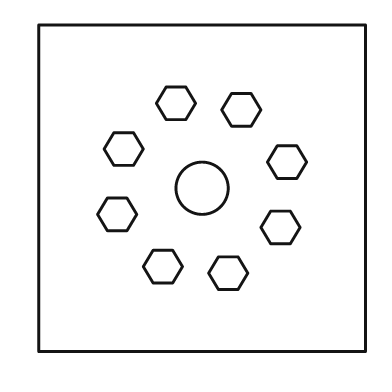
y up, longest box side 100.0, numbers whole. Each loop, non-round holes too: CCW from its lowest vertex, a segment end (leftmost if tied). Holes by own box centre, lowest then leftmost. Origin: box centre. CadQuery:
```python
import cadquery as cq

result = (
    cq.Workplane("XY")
    .moveTo(-50.0, -50.0)
    .lineTo(50.0, -50.0)
    .lineTo(50.0, 50.0)
    .lineTo(-50.0, 50.0)
    .close()
    .moveTo(5.0, -31.0)
    .lineTo(11.0, -31.0)
    .lineTo(14.0, -26.0)
    .lineTo(11.0, -21.0)
    .lineTo(5.0, -21.0)
    .lineTo(2.0, -26.0)
    .close()
    .moveTo(-15.0, -29.0)
    .lineTo(-9.0, -29.0)
    .lineTo(-6.0, -24.0)
    .lineTo(-9.0, -19.0)
    .lineTo(-15.0, -19.0)
    .lineTo(-18.0, -24.0)
    .close()
    .moveTo(21.0, -17.0)
    .lineTo(27.0, -17.0)
    .lineTo(30.0, -12.0)
    .lineTo(27.0, -7.0)
    .lineTo(21.0, -7.0)
    .lineTo(18.0, -12.0)
    .close()
    .moveTo(-29.0, -13.0)
    .lineTo(-23.0, -13.0)
    .lineTo(-20.0, -8.0)
    .lineTo(-23.0, -3.0)
    .lineTo(-29.0, -3.0)
    .lineTo(-32.0, -8.0)
    .close()
    .moveTo(0.0, 0.0)
    .circle(8.0)
    .moveTo(23.0, 3.0)
    .lineTo(29.0, 3.0)
    .lineTo(32.0, 8.0)
    .lineTo(29.0, 13.0)
    .lineTo(23.0, 13.0)
    .lineTo(20.0, 8.0)
    .close()
    .moveTo(-27.0, 7.0)
    .lineTo(-21.0, 7.0)
    .lineTo(-18.0, 12.0)
    .lineTo(-21.0, 17.0)
    .lineTo(-27.0, 17.0)
    .lineTo(-30.0, 12.0)
    .close()
    .moveTo(9.0, 19.0)
    .lineTo(15.0, 19.0)
    .lineTo(18.0, 24.0)
    .lineTo(15.0, 29.0)
    .lineTo(9.0, 29.0)
    .lineTo(6.0, 24.0)
    .close()
    .moveTo(-11.0, 21.0)
    .lineTo(-5.0, 21.0)
    .lineTo(-2.0, 26.0)
    .lineTo(-5.0, 31.0)
    .lineTo(-11.0, 31.0)
    .lineTo(-14.0, 26.0)
    .close()
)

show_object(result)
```